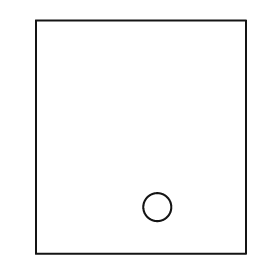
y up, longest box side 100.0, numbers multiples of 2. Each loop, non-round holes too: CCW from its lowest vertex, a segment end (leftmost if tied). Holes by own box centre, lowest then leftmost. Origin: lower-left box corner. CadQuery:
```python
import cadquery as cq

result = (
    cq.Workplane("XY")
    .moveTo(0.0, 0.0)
    .lineTo(90.0, 0.0)
    .lineTo(90.0, 100.0)
    .lineTo(0.0, 100.0)
    .close()
    .moveTo(52.0, 20.0)
    .circle(6.0)
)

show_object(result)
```